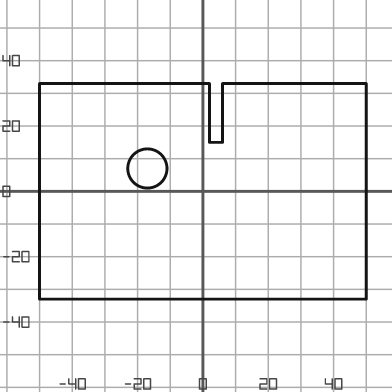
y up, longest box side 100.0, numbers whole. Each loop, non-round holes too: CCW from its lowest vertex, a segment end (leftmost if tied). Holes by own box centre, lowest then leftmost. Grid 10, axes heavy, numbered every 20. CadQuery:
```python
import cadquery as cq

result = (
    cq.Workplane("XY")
    .moveTo(-50.0, -33.0)
    .lineTo(50.0, -33.0)
    .lineTo(50.0, 33.0)
    .lineTo(6.0, 33.0)
    .lineTo(6.0, 15.0)
    .lineTo(2.0, 15.0)
    .lineTo(2.0, 33.0)
    .lineTo(-50.0, 33.0)
    .close()
    .moveTo(-17.0, 7.0)
    .circle(6.0)
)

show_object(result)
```